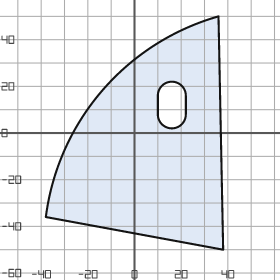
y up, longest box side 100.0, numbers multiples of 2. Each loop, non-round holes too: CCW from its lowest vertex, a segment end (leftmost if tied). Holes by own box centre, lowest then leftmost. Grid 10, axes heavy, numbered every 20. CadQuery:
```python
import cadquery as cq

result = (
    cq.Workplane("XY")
    .moveTo(38.0, -50.0)
    .lineTo(36.0, 50.0)
    .threePointArc((-14.0, 18.0), (-38.0, -36.0))
    .close()
    .moveTo(10.0, 8.0)
    .threePointArc((16.0, 2.0), (22.0, 8.0))
    .lineTo(22.0, 16.0)
    .threePointArc((16.0, 22.0), (10.0, 16.0))
    .close()
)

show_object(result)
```